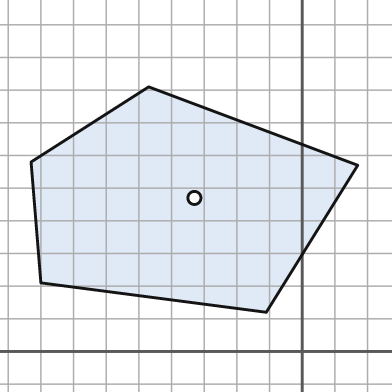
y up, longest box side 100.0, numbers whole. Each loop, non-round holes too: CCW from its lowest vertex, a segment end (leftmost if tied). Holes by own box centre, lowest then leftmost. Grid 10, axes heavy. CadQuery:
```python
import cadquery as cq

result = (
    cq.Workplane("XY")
    .moveTo(-11.0, 12.0)
    .lineTo(17.0, 57.0)
    .lineTo(-47.0, 81.0)
    .lineTo(-83.0, 58.0)
    .lineTo(-80.0, 21.0)
    .close()
    .moveTo(-33.0, 47.0)
    .circle(2.0)
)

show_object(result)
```